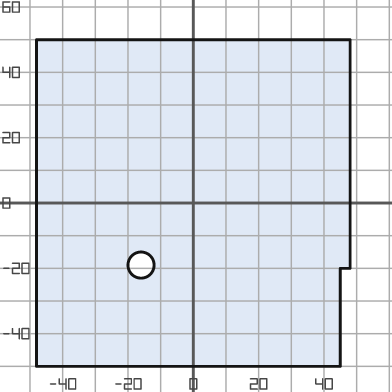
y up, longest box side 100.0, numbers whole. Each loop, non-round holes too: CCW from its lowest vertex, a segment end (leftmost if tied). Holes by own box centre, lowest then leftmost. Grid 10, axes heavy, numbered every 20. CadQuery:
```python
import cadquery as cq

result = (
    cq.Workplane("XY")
    .moveTo(-48.0, -50.0)
    .lineTo(45.0, -50.0)
    .lineTo(45.0, -20.0)
    .lineTo(48.0, -20.0)
    .lineTo(48.0, 50.0)
    .lineTo(-48.0, 50.0)
    .close()
    .moveTo(-16.0, -19.0)
    .circle(4.0)
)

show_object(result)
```